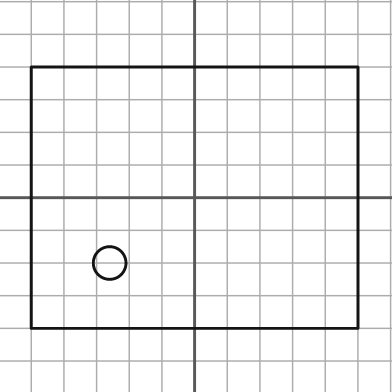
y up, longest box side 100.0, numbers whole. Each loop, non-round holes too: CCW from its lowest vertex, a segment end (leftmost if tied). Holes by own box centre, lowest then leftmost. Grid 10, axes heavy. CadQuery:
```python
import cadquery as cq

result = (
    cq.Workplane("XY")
    .moveTo(-50.0, -40.0)
    .lineTo(50.0, -40.0)
    .lineTo(50.0, 40.0)
    .lineTo(-50.0, 40.0)
    .close()
    .moveTo(-26.0, -20.0)
    .circle(5.0)
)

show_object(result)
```